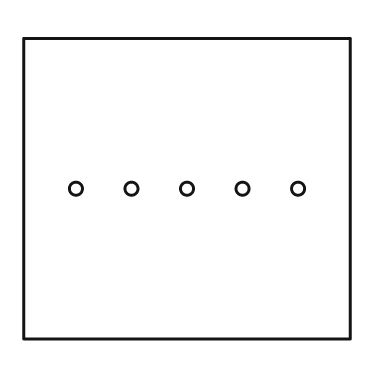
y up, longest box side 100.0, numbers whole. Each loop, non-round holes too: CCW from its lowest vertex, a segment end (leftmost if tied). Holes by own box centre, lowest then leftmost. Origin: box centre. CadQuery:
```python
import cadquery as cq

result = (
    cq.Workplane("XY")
    .moveTo(-50.0, -46.0)
    .lineTo(50.0, -46.0)
    .lineTo(50.0, 46.0)
    .lineTo(-50.0, 46.0)
    .close()
    .moveTo(-34.0, 0.0)
    .circle(2.0)
    .moveTo(-17.0, 0.0)
    .circle(2.0)
    .moveTo(0.0, 0.0)
    .circle(2.0)
    .moveTo(17.0, 0.0)
    .circle(2.0)
    .moveTo(34.0, 0.0)
    .circle(2.0)
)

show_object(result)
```